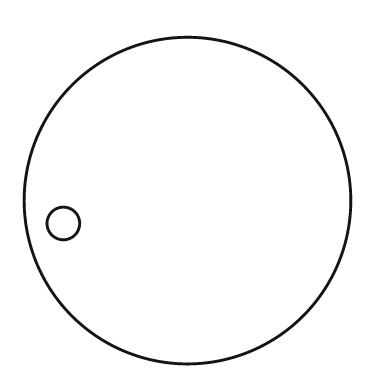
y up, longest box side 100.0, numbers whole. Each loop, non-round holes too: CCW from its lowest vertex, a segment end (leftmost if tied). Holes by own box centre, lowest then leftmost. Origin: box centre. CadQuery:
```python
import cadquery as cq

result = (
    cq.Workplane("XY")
    .moveTo(0.0, 0.0)
    .circle(50.0)
    .moveTo(-38.0, -7.0)
    .circle(5.0)
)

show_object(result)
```